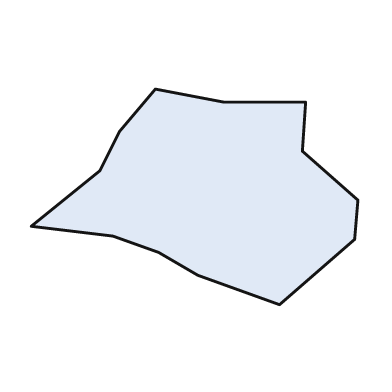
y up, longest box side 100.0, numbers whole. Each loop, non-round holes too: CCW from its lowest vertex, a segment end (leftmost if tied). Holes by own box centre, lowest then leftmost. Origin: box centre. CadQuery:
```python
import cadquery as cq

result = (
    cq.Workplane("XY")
    .moveTo(26.0, -33.0)
    .lineTo(49.0, -13.0)
    .lineTo(50.0, -1.0)
    .lineTo(33.0, 14.0)
    .lineTo(34.0, 29.0)
    .lineTo(9.0, 29.0)
    .lineTo(-12.0, 33.0)
    .lineTo(-23.0, 20.0)
    .lineTo(-29.0, 8.0)
    .lineTo(-50.0, -9.0)
    .lineTo(-25.0, -12.0)
    .lineTo(-11.0, -17.0)
    .lineTo(1.0, -24.0)
    .close()
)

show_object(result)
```